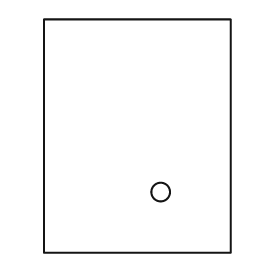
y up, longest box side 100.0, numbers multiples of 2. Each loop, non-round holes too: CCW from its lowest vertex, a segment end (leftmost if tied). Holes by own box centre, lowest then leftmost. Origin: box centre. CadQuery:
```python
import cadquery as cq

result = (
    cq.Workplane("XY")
    .moveTo(-40.0, -50.0)
    .lineTo(40.0, -50.0)
    .lineTo(40.0, 50.0)
    .lineTo(-40.0, 50.0)
    .close()
    .moveTo(10.0, -24.0)
    .circle(4.0)
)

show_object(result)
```